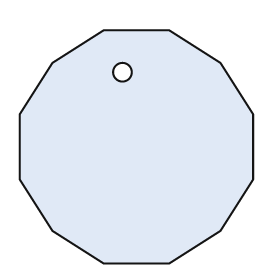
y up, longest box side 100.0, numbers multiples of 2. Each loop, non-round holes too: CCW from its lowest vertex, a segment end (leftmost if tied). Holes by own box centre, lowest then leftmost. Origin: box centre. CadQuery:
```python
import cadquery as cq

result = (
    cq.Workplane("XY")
    .moveTo(-14.0, -50.0)
    .lineTo(14.0, -50.0)
    .lineTo(36.0, -36.0)
    .lineTo(50.0, -14.0)
    .lineTo(50.0, 14.0)
    .lineTo(36.0, 36.0)
    .lineTo(14.0, 50.0)
    .lineTo(-14.0, 50.0)
    .lineTo(-36.0, 36.0)
    .lineTo(-50.0, 14.0)
    .lineTo(-50.0, -14.0)
    .lineTo(-36.0, -36.0)
    .close()
    .moveTo(-6.0, 32.0)
    .circle(4.0)
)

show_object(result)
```